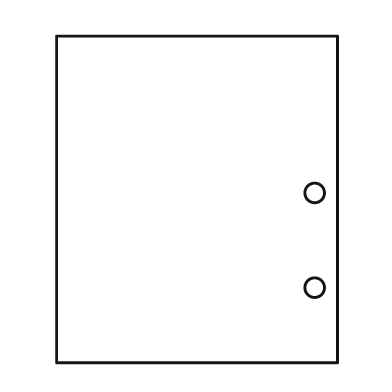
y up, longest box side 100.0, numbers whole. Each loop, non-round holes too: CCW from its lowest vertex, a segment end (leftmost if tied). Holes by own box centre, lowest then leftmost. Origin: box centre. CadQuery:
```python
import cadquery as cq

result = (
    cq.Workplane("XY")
    .moveTo(-43.0, -50.0)
    .lineTo(43.0, -50.0)
    .lineTo(43.0, 50.0)
    .lineTo(-43.0, 50.0)
    .close()
    .moveTo(36.0, -27.0)
    .circle(3.0)
    .moveTo(36.0, 2.0)
    .circle(3.0)
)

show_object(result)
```